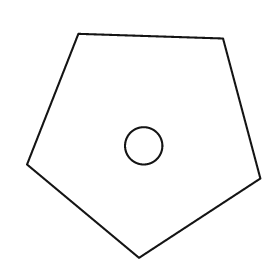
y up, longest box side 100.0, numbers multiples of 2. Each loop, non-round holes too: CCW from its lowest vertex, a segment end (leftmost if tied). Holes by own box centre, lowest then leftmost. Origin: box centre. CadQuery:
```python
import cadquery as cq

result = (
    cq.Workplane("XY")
    .moveTo(-2.0, -48.0)
    .lineTo(50.0, -14.0)
    .lineTo(34.0, 46.0)
    .lineTo(-28.0, 48.0)
    .lineTo(-50.0, -8.0)
    .close()
    .moveTo(0.0, 0.0)
    .circle(8.0)
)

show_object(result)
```